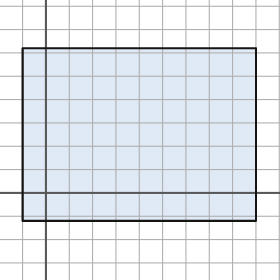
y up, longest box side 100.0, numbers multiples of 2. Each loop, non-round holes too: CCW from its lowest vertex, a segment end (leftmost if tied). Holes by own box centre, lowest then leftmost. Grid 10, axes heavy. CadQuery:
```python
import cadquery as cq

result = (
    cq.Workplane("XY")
    .moveTo(-10.0, -12.0)
    .lineTo(90.0, -12.0)
    .lineTo(90.0, 62.0)
    .lineTo(-10.0, 62.0)
    .close()
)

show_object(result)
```